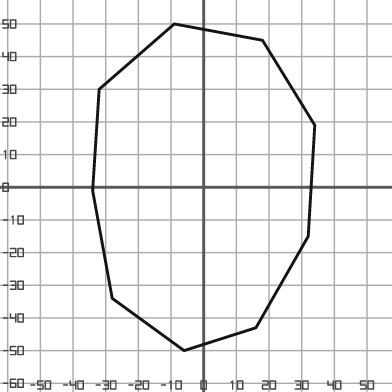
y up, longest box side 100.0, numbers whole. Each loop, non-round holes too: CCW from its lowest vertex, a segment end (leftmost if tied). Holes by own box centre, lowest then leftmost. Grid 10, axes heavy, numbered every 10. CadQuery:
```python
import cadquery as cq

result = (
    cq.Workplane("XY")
    .moveTo(-6.0, -50.0)
    .lineTo(16.0, -43.0)
    .lineTo(32.0, -15.0)
    .lineTo(34.0, 19.0)
    .lineTo(18.0, 45.0)
    .lineTo(-9.0, 50.0)
    .lineTo(-32.0, 30.0)
    .lineTo(-34.0, -1.0)
    .lineTo(-28.0, -34.0)
    .close()
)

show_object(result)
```